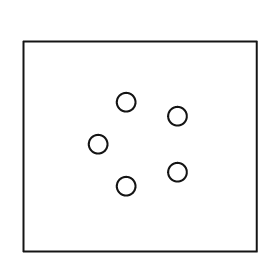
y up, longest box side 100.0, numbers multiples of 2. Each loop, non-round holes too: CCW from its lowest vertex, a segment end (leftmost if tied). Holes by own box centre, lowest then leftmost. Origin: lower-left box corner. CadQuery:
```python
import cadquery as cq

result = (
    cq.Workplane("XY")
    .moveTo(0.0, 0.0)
    .lineTo(100.0, 0.0)
    .lineTo(100.0, 90.0)
    .lineTo(0.0, 90.0)
    .close()
    .moveTo(44.0, 28.0)
    .circle(4.0)
    .moveTo(66.0, 34.0)
    .circle(4.0)
    .moveTo(32.0, 46.0)
    .circle(4.0)
    .moveTo(66.0, 58.0)
    .circle(4.0)
    .moveTo(44.0, 64.0)
    .circle(4.0)
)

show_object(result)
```